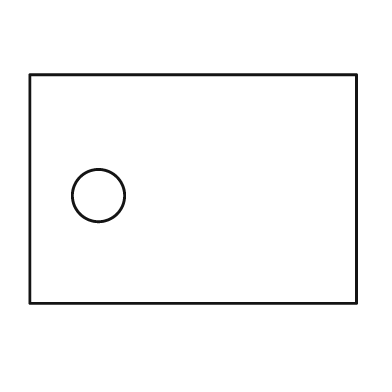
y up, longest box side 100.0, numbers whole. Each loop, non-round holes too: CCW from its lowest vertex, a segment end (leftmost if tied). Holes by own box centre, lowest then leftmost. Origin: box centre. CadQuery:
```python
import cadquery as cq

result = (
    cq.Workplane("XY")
    .moveTo(-50.0, -35.0)
    .lineTo(50.0, -35.0)
    .lineTo(50.0, 35.0)
    .lineTo(-50.0, 35.0)
    .close()
    .moveTo(-29.0, -2.0)
    .circle(8.0)
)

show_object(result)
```